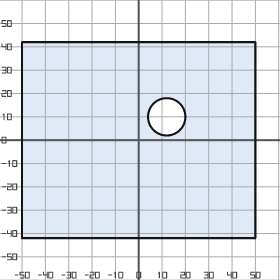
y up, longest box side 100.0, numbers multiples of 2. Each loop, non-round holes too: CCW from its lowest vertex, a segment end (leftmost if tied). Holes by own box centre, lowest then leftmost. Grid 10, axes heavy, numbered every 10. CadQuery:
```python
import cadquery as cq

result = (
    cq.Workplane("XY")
    .moveTo(-50.0, -42.0)
    .lineTo(50.0, -42.0)
    .lineTo(50.0, 42.0)
    .lineTo(-50.0, 42.0)
    .close()
    .moveTo(12.0, 10.0)
    .circle(8.0)
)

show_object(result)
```